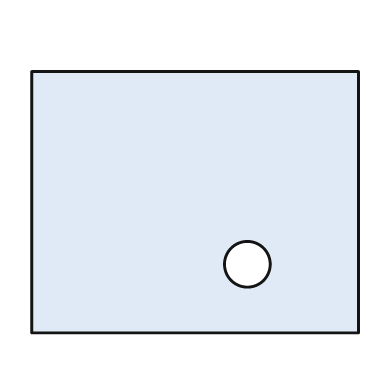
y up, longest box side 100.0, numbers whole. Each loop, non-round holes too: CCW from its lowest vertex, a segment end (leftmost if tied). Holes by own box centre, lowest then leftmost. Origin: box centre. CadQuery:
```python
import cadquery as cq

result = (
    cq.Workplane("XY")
    .moveTo(-50.0, -40.0)
    .lineTo(50.0, -40.0)
    .lineTo(50.0, 40.0)
    .lineTo(-50.0, 40.0)
    .close()
    .moveTo(16.0, -19.0)
    .circle(7.0)
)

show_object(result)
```